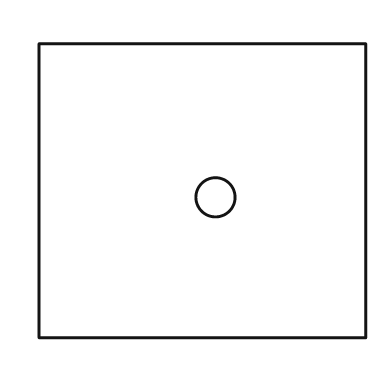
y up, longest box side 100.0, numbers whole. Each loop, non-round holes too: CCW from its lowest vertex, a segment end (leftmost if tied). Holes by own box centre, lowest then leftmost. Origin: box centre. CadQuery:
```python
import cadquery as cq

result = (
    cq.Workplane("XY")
    .moveTo(-50.0, -45.0)
    .lineTo(50.0, -45.0)
    .lineTo(50.0, 45.0)
    .lineTo(-50.0, 45.0)
    .close()
    .moveTo(4.0, -2.0)
    .circle(6.0)
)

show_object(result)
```